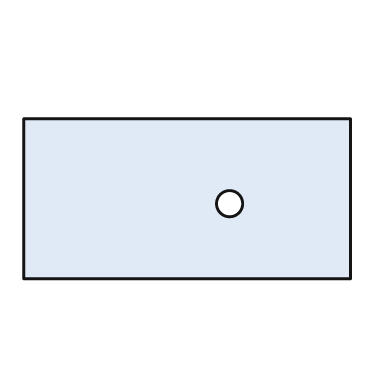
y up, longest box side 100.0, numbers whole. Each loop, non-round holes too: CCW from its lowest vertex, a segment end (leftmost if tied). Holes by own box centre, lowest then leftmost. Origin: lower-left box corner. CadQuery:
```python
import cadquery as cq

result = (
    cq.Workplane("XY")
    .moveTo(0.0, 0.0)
    .lineTo(100.0, 0.0)
    .lineTo(100.0, 49.0)
    .lineTo(0.0, 49.0)
    .close()
    .moveTo(63.0, 23.0)
    .circle(4.0)
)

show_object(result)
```